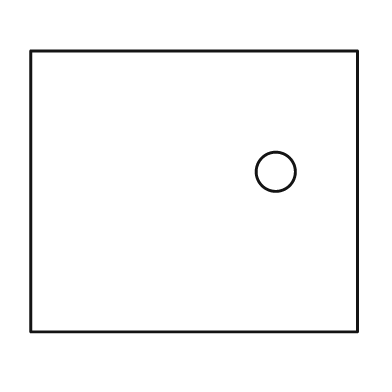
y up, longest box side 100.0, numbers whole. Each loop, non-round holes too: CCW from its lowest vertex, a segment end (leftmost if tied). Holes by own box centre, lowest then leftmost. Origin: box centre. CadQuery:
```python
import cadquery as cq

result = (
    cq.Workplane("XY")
    .moveTo(-50.0, -43.0)
    .lineTo(50.0, -43.0)
    .lineTo(50.0, 43.0)
    .lineTo(-50.0, 43.0)
    .close()
    .moveTo(25.0, 6.0)
    .circle(6.0)
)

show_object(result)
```